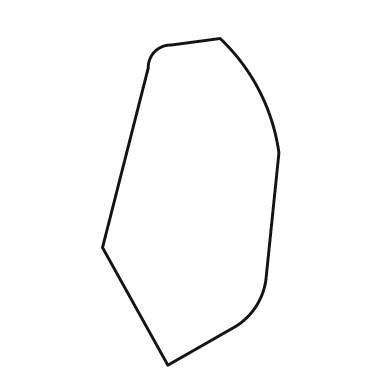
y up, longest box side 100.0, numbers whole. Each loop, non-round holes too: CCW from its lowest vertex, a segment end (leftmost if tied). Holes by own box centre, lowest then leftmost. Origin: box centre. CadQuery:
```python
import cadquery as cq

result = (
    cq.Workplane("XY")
    .moveTo(-7.0, -50.0)
    .lineTo(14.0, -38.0)
    .threePointArc((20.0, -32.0), (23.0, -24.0))
    .lineTo(27.0, 15.0)
    .threePointArc((21.0, 34.0), (9.0, 50.0))
    .lineTo(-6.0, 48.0)
    .threePointArc((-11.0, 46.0), (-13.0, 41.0))
    .lineTo(-27.0, -14.0)
    .close()
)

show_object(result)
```